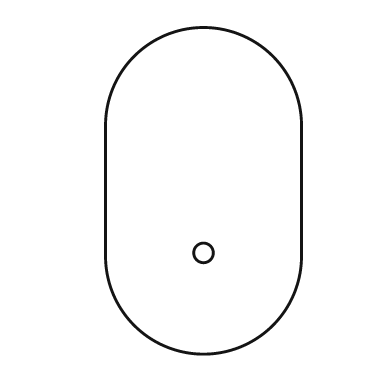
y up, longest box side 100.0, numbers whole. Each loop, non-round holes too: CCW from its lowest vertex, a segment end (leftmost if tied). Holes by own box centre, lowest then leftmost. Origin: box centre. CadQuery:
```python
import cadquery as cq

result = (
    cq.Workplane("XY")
    .moveTo(-30.0, -20.0)
    .threePointArc((0.0, -50.0), (30.0, -20.0))
    .lineTo(30.0, 20.0)
    .threePointArc((0.0, 50.0), (-30.0, 20.0))
    .close()
    .moveTo(0.0, -19.0)
    .circle(3.0)
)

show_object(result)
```